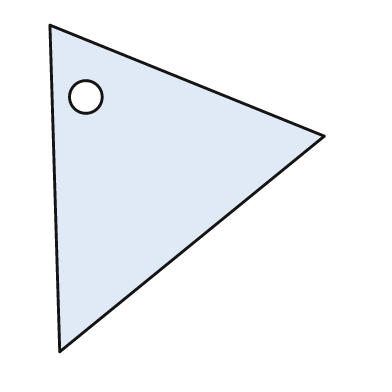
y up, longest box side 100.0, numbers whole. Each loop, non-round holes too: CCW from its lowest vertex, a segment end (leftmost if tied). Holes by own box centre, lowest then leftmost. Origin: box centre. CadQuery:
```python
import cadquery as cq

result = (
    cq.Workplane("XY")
    .moveTo(-39.0, -50.0)
    .lineTo(42.0, 16.0)
    .lineTo(-42.0, 50.0)
    .close()
    .moveTo(-31.0, 28.0)
    .circle(5.0)
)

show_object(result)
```